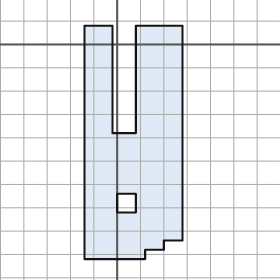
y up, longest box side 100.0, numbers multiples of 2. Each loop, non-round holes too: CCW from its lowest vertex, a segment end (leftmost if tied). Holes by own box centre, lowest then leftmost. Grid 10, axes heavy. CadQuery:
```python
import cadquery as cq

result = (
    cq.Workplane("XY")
    .moveTo(-14.0, -92.0)
    .lineTo(12.0, -92.0)
    .lineTo(12.0, -88.0)
    .lineTo(20.0, -88.0)
    .lineTo(20.0, -84.0)
    .lineTo(28.0, -84.0)
    .lineTo(28.0, 8.0)
    .lineTo(8.0, 8.0)
    .lineTo(8.0, -38.0)
    .lineTo(-2.0, -38.0)
    .lineTo(-2.0, 8.0)
    .lineTo(-14.0, 8.0)
    .close()
    .moveTo(0.0, -72.0)
    .lineTo(8.0, -72.0)
    .lineTo(8.0, -64.0)
    .lineTo(0.0, -64.0)
    .close()
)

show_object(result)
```